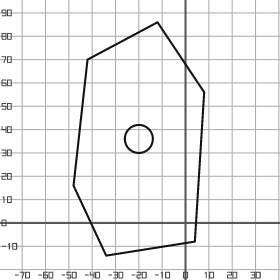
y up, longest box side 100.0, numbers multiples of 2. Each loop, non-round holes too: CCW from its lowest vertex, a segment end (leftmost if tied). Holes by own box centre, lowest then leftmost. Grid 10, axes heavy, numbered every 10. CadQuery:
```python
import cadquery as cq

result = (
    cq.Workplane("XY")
    .moveTo(-34.0, -14.0)
    .lineTo(4.0, -8.0)
    .lineTo(8.0, 56.0)
    .lineTo(-12.0, 86.0)
    .lineTo(-42.0, 70.0)
    .lineTo(-48.0, 16.0)
    .close()
    .moveTo(-20.0, 36.0)
    .circle(6.0)
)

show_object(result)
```